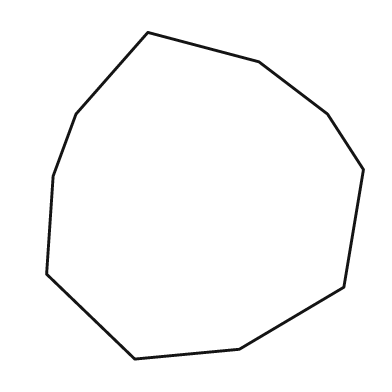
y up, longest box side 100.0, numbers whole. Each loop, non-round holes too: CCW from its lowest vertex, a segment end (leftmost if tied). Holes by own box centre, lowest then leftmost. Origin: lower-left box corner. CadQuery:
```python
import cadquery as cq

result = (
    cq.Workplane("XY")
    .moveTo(27.0, 0.0)
    .lineTo(59.0, 3.0)
    .lineTo(91.0, 22.0)
    .lineTo(97.0, 58.0)
    .lineTo(86.0, 75.0)
    .lineTo(65.0, 91.0)
    .lineTo(31.0, 100.0)
    .lineTo(9.0, 75.0)
    .lineTo(2.0, 56.0)
    .lineTo(0.0, 26.0)
    .close()
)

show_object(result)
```